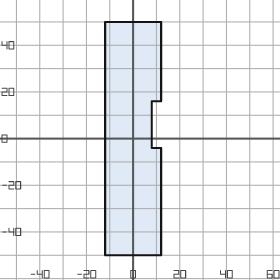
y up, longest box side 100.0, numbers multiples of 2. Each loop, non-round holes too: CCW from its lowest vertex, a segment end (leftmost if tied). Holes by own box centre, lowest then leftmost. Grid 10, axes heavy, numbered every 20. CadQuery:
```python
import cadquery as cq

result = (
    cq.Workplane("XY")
    .moveTo(-12.0, -50.0)
    .lineTo(12.0, -50.0)
    .lineTo(12.0, -4.0)
    .lineTo(8.0, -4.0)
    .lineTo(8.0, 16.0)
    .lineTo(12.0, 16.0)
    .lineTo(12.0, 50.0)
    .lineTo(-12.0, 50.0)
    .close()
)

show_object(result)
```